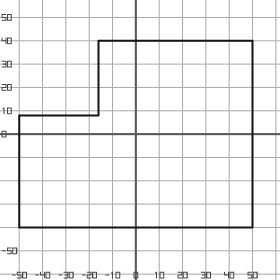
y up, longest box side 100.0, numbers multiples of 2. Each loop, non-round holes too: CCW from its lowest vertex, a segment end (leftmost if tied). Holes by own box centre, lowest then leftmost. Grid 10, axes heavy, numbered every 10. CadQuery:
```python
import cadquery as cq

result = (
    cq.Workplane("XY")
    .moveTo(-50.0, -40.0)
    .lineTo(50.0, -40.0)
    .lineTo(50.0, 40.0)
    .lineTo(-16.0, 40.0)
    .lineTo(-16.0, 8.0)
    .lineTo(-50.0, 8.0)
    .close()
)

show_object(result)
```